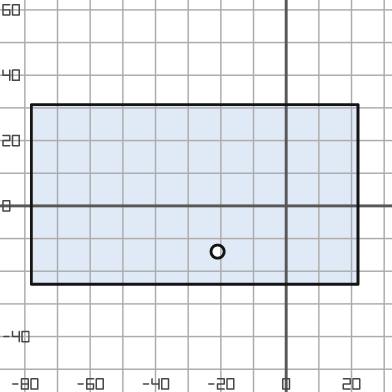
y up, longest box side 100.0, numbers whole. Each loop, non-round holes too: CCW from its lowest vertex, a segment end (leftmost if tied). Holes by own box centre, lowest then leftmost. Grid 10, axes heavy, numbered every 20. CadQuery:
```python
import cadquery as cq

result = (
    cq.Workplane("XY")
    .moveTo(-78.0, -24.0)
    .lineTo(22.0, -24.0)
    .lineTo(22.0, 31.0)
    .lineTo(-78.0, 31.0)
    .close()
    .moveTo(-21.0, -14.0)
    .circle(2.0)
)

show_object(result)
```